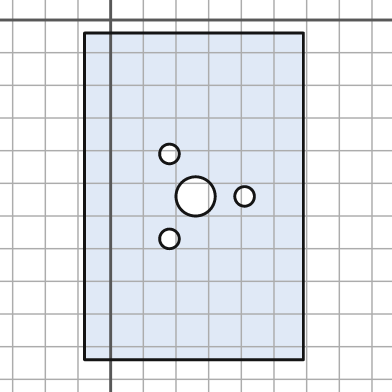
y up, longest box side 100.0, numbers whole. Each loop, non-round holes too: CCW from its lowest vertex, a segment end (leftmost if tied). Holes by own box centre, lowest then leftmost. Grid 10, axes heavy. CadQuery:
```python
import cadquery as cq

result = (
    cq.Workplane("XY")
    .moveTo(-8.0, -104.0)
    .lineTo(59.0, -104.0)
    .lineTo(59.0, -4.0)
    .lineTo(-8.0, -4.0)
    .close()
    .moveTo(18.0, -67.0)
    .circle(3.0)
    .moveTo(26.0, -54.0)
    .circle(6.0)
    .moveTo(41.0, -54.0)
    .circle(3.0)
    .moveTo(18.0, -41.0)
    .circle(3.0)
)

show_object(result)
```